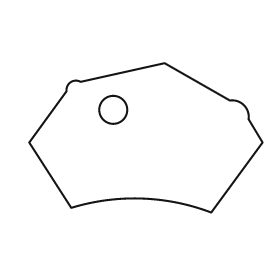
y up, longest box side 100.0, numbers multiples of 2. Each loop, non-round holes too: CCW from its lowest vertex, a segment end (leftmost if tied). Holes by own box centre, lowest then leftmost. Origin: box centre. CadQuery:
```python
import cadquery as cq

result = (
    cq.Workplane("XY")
    .moveTo(28.0, -32.0)
    .lineTo(50.0, -2.0)
    .lineTo(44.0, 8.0)
    .threePointArc((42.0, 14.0), (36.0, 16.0))
    .lineTo(8.0, 32.0)
    .lineTo(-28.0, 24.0)
    .threePointArc((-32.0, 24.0), (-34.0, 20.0))
    .lineTo(-50.0, -2.0)
    .lineTo(-32.0, -30.0)
    .threePointArc((-2.0, -26.0), (28.0, -32.0))
    .close()
    .moveTo(-14.0, 12.0)
    .circle(6.0)
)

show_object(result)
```